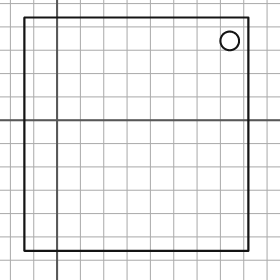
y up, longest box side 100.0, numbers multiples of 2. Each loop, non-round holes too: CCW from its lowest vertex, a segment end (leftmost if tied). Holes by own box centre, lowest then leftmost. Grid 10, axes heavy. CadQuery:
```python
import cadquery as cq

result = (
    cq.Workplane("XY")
    .moveTo(-14.0, -56.0)
    .lineTo(82.0, -56.0)
    .lineTo(82.0, 44.0)
    .lineTo(-14.0, 44.0)
    .close()
    .moveTo(74.0, 34.0)
    .circle(4.0)
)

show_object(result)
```